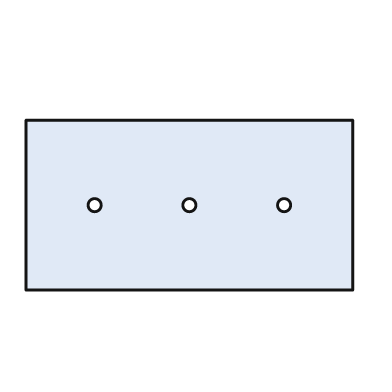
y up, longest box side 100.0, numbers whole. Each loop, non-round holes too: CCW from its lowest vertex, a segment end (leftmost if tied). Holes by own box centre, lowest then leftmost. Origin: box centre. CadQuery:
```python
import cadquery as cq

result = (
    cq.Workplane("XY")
    .moveTo(-50.0, -26.0)
    .lineTo(50.0, -26.0)
    .lineTo(50.0, 26.0)
    .lineTo(-50.0, 26.0)
    .close()
    .moveTo(-29.0, 0.0)
    .circle(2.0)
    .moveTo(0.0, 0.0)
    .circle(2.0)
    .moveTo(29.0, 0.0)
    .circle(2.0)
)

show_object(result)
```